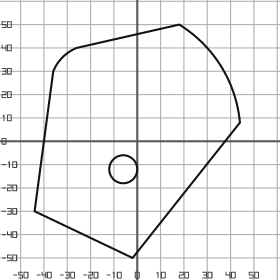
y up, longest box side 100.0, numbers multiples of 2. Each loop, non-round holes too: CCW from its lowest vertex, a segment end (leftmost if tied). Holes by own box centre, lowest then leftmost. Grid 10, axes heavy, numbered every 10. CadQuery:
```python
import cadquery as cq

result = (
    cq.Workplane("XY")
    .moveTo(-2.0, -50.0)
    .lineTo(44.0, 8.0)
    .threePointArc((36.0, 32.0), (18.0, 50.0))
    .lineTo(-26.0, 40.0)
    .threePointArc((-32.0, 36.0), (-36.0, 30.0))
    .lineTo(-44.0, -30.0)
    .close()
    .moveTo(-6.0, -12.0)
    .circle(6.0)
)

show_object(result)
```